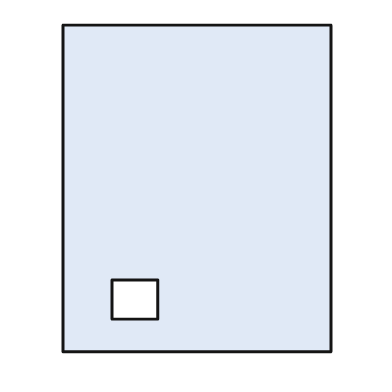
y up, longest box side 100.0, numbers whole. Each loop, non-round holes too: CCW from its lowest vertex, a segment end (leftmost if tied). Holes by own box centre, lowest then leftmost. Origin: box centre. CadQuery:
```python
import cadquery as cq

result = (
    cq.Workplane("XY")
    .moveTo(-41.0, -50.0)
    .lineTo(41.0, -50.0)
    .lineTo(41.0, 50.0)
    .lineTo(-41.0, 50.0)
    .close()
    .moveTo(-26.0, -40.0)
    .lineTo(-12.0, -40.0)
    .lineTo(-12.0, -28.0)
    .lineTo(-26.0, -28.0)
    .close()
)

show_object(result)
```